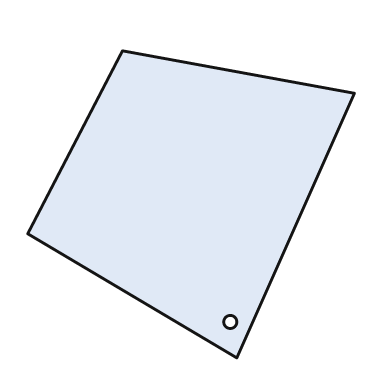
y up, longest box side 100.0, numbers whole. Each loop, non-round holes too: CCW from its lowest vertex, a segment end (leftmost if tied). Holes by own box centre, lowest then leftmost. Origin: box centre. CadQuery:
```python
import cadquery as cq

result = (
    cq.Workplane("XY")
    .moveTo(14.0, -47.0)
    .lineTo(50.0, 34.0)
    .lineTo(-21.0, 47.0)
    .lineTo(-50.0, -9.0)
    .close()
    .moveTo(12.0, -36.0)
    .circle(2.0)
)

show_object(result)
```